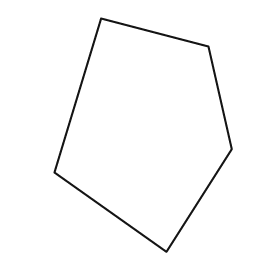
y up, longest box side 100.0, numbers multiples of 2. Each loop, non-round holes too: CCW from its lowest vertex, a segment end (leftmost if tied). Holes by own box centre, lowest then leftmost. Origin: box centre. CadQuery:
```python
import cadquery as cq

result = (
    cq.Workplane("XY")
    .moveTo(10.0, -50.0)
    .lineTo(38.0, -6.0)
    .lineTo(28.0, 38.0)
    .lineTo(-18.0, 50.0)
    .lineTo(-38.0, -16.0)
    .close()
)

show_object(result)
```